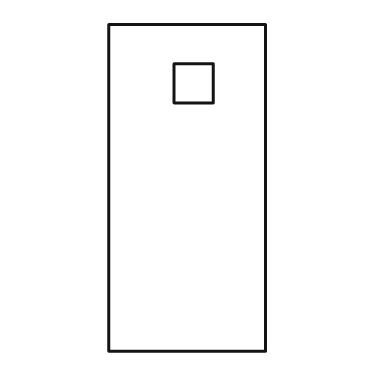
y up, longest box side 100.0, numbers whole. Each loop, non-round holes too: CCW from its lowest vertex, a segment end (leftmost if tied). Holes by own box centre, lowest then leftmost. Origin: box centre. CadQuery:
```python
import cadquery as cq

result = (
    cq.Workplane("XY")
    .moveTo(-24.0, -50.0)
    .lineTo(24.0, -50.0)
    .lineTo(24.0, 50.0)
    .lineTo(-24.0, 50.0)
    .close()
    .moveTo(-4.0, 26.0)
    .lineTo(8.0, 26.0)
    .lineTo(8.0, 38.0)
    .lineTo(-4.0, 38.0)
    .close()
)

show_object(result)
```